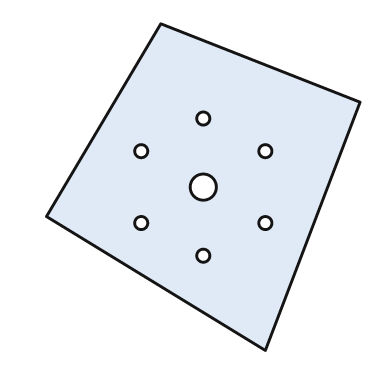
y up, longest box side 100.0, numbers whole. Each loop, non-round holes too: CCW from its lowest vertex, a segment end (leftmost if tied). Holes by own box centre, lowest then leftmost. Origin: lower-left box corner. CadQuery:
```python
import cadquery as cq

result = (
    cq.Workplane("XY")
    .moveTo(67.0, 0.0)
    .lineTo(96.0, 76.0)
    .lineTo(35.0, 100.0)
    .lineTo(0.0, 41.0)
    .close()
    .moveTo(48.0, 29.0)
    .circle(2.0)
    .moveTo(29.0, 39.0)
    .circle(2.0)
    .moveTo(67.0, 39.0)
    .circle(2.0)
    .moveTo(48.0, 50.0)
    .circle(4.0)
    .moveTo(29.0, 61.0)
    .circle(2.0)
    .moveTo(67.0, 61.0)
    .circle(2.0)
    .moveTo(48.0, 71.0)
    .circle(2.0)
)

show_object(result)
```